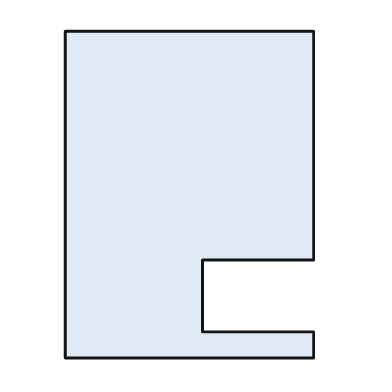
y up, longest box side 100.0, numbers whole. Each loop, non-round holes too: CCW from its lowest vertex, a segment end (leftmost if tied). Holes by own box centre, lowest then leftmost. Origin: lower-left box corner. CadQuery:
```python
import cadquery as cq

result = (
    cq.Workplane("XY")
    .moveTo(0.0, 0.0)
    .lineTo(76.0, 0.0)
    .lineTo(76.0, 8.0)
    .lineTo(42.0, 8.0)
    .lineTo(42.0, 30.0)
    .lineTo(76.0, 30.0)
    .lineTo(76.0, 100.0)
    .lineTo(0.0, 100.0)
    .close()
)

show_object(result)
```